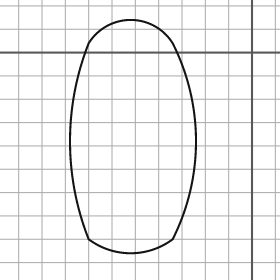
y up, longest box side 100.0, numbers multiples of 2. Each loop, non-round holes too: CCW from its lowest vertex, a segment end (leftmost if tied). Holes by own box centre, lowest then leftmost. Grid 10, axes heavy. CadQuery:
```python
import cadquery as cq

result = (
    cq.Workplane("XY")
    .moveTo(-70.0, -80.0)
    .threePointArc((-52.0, -86.0), (-34.0, -80.0))
    .threePointArc((-24.0, -38.0), (-34.0, 4.0))
    .threePointArc((-52.0, 14.0), (-70.0, 4.0))
    .threePointArc((-78.0, -38.0), (-70.0, -80.0))
    .close()
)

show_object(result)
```